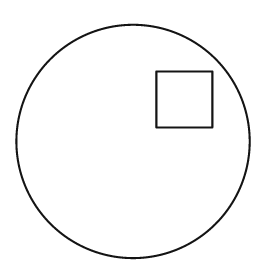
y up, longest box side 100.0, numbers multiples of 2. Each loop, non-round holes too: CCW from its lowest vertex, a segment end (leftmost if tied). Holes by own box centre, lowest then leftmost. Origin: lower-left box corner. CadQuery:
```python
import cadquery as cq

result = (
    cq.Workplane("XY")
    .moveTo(50.0, 50.0)
    .circle(50.0)
    .moveTo(60.0, 56.0)
    .lineTo(84.0, 56.0)
    .lineTo(84.0, 80.0)
    .lineTo(60.0, 80.0)
    .close()
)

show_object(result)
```